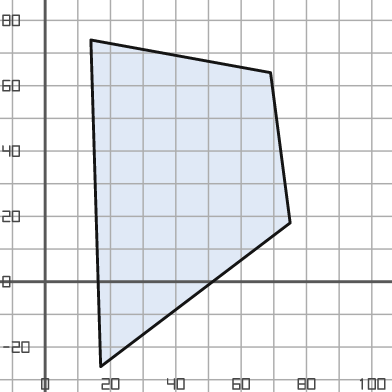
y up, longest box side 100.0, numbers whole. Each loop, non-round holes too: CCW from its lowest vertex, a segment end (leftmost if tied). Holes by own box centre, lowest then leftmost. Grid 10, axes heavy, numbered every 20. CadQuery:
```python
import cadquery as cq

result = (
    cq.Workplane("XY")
    .moveTo(17.0, -26.0)
    .lineTo(75.0, 18.0)
    .lineTo(69.0, 64.0)
    .lineTo(14.0, 74.0)
    .close()
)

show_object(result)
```